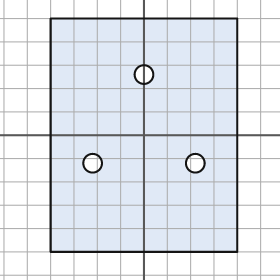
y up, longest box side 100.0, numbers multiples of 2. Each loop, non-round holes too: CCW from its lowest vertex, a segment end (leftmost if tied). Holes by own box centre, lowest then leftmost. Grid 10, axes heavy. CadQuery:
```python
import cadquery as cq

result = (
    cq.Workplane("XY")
    .moveTo(-40.0, -50.0)
    .lineTo(40.0, -50.0)
    .lineTo(40.0, 50.0)
    .lineTo(-40.0, 50.0)
    .close()
    .moveTo(-22.0, -12.0)
    .circle(4.0)
    .moveTo(22.0, -12.0)
    .circle(4.0)
    .moveTo(0.0, 26.0)
    .circle(4.0)
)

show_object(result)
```